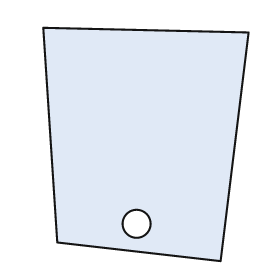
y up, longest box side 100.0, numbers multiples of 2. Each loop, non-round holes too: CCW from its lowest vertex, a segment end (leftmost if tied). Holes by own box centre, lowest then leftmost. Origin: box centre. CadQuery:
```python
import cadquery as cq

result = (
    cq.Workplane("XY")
    .moveTo(32.0, -50.0)
    .lineTo(44.0, 48.0)
    .lineTo(-44.0, 50.0)
    .lineTo(-38.0, -42.0)
    .close()
    .moveTo(-4.0, -34.0)
    .circle(6.0)
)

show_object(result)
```